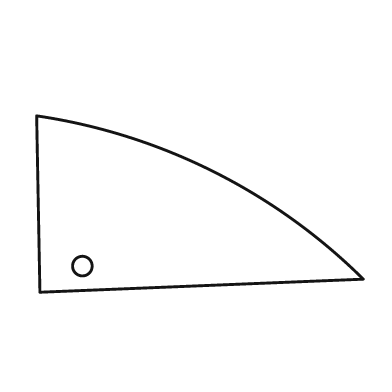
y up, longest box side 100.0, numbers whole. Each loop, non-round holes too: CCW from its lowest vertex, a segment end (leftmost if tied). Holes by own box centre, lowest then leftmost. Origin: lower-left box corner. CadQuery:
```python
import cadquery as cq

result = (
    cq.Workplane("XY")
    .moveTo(1.0, 0.0)
    .lineTo(100.0, 4.0)
    .threePointArc((54.0, 37.0), (0.0, 54.0))
    .close()
    .moveTo(14.0, 8.0)
    .circle(3.0)
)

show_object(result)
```